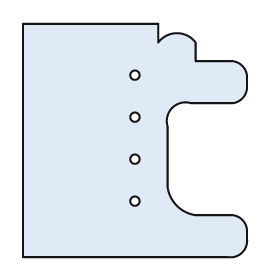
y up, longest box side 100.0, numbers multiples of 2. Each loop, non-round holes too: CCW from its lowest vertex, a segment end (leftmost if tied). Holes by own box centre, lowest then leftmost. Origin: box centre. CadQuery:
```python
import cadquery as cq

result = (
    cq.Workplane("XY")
    .moveTo(-48.0, -50.0)
    .lineTo(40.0, -50.0)
    .threePointArc((46.0, -48.0), (48.0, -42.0))
    .lineTo(48.0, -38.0)
    .threePointArc((46.0, -34.0), (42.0, -32.0))
    .lineTo(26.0, -32.0)
    .threePointArc((18.0, -28.0), (14.0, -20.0))
    .lineTo(14.0, 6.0)
    .threePointArc((16.0, 14.0), (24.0, 16.0))
    .lineTo(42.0, 16.0)
    .threePointArc((46.0, 18.0), (48.0, 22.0))
    .lineTo(48.0, 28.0)
    .threePointArc((46.0, 32.0), (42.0, 34.0))
    .lineTo(26.0, 34.0)
    .lineTo(26.0, 42.0)
    .threePointArc((18.0, 46.0), (10.0, 42.0))
    .lineTo(10.0, 50.0)
    .lineTo(-48.0, 50.0)
    .close()
    .moveTo(0.0, -26.0)
    .circle(2.0)
    .moveTo(0.0, -8.0)
    .circle(2.0)
    .moveTo(0.0, 10.0)
    .circle(2.0)
    .moveTo(0.0, 28.0)
    .circle(2.0)
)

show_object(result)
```